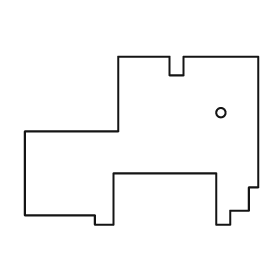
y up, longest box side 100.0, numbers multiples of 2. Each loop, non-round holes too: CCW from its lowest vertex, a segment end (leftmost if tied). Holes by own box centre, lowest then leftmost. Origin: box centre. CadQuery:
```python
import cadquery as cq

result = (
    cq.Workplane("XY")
    .moveTo(-20.0, -36.0)
    .lineTo(-12.0, -36.0)
    .lineTo(-12.0, -14.0)
    .lineTo(32.0, -14.0)
    .lineTo(32.0, -36.0)
    .lineTo(38.0, -36.0)
    .lineTo(38.0, -30.0)
    .lineTo(46.0, -30.0)
    .lineTo(46.0, -20.0)
    .lineTo(50.0, -20.0)
    .lineTo(50.0, 36.0)
    .lineTo(18.0, 36.0)
    .lineTo(18.0, 28.0)
    .lineTo(12.0, 28.0)
    .lineTo(12.0, 36.0)
    .lineTo(-10.0, 36.0)
    .lineTo(-10.0, 4.0)
    .lineTo(-50.0, 4.0)
    .lineTo(-50.0, -32.0)
    .lineTo(-20.0, -32.0)
    .close()
    .moveTo(34.0, 12.0)
    .circle(2.0)
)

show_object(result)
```